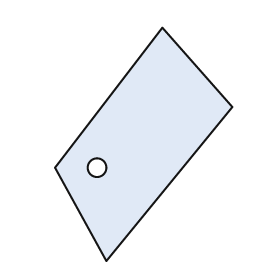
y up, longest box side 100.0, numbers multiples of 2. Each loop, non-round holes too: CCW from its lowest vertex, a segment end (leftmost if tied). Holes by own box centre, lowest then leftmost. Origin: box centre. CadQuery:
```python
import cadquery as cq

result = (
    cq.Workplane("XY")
    .moveTo(-16.0, -50.0)
    .lineTo(38.0, 16.0)
    .lineTo(8.0, 50.0)
    .lineTo(-38.0, -10.0)
    .close()
    .moveTo(-20.0, -10.0)
    .circle(4.0)
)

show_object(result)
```